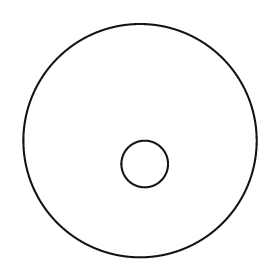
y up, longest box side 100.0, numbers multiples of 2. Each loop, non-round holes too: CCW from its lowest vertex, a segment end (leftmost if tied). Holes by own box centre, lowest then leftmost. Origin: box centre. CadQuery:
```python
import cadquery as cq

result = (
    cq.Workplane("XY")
    .moveTo(0.0, 0.0)
    .circle(50.0)
    .moveTo(2.0, -10.0)
    .circle(10.0)
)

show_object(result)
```